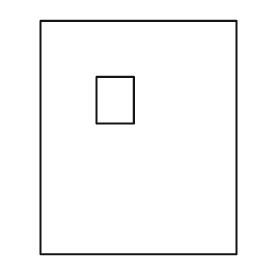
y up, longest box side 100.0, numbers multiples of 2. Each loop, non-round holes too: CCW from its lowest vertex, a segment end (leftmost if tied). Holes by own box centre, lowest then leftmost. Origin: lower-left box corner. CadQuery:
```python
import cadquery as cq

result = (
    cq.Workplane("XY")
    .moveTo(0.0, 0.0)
    .lineTo(84.0, 0.0)
    .lineTo(84.0, 100.0)
    .lineTo(0.0, 100.0)
    .close()
    .moveTo(24.0, 56.0)
    .lineTo(40.0, 56.0)
    .lineTo(40.0, 76.0)
    .lineTo(24.0, 76.0)
    .close()
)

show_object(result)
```